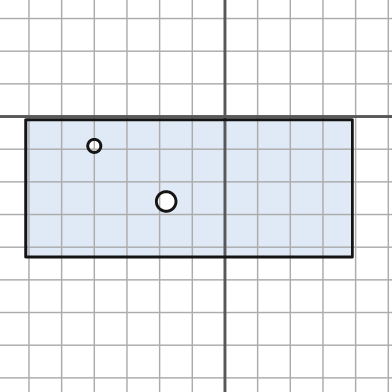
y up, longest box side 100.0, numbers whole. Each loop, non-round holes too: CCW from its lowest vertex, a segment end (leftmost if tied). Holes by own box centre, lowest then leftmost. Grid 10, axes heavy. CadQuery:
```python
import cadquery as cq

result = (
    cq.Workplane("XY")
    .moveTo(-61.0, -43.0)
    .lineTo(39.0, -43.0)
    .lineTo(39.0, -1.0)
    .lineTo(-61.0, -1.0)
    .close()
    .moveTo(-18.0, -26.0)
    .circle(3.0)
    .moveTo(-40.0, -9.0)
    .circle(2.0)
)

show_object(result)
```